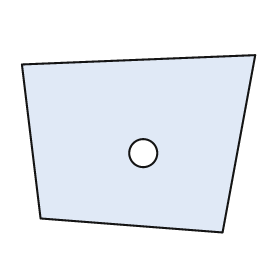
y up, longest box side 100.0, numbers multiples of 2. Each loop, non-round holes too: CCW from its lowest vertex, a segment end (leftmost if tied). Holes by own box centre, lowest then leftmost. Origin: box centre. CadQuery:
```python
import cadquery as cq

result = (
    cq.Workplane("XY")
    .moveTo(36.0, -38.0)
    .lineTo(50.0, 38.0)
    .lineTo(-50.0, 34.0)
    .lineTo(-42.0, -32.0)
    .close()
    .moveTo(2.0, -4.0)
    .circle(6.0)
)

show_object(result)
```